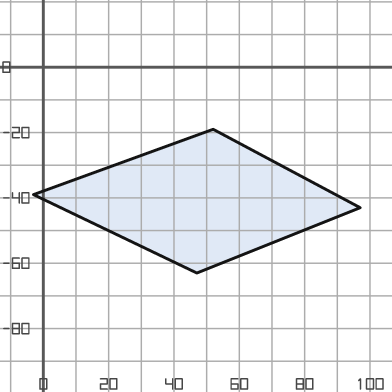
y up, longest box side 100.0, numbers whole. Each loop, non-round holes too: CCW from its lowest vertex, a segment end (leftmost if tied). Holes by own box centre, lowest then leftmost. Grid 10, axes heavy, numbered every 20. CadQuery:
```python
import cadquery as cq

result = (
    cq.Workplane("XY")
    .moveTo(47.0, -63.0)
    .lineTo(97.0, -43.0)
    .lineTo(52.0, -19.0)
    .lineTo(-3.0, -39.0)
    .close()
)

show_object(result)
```